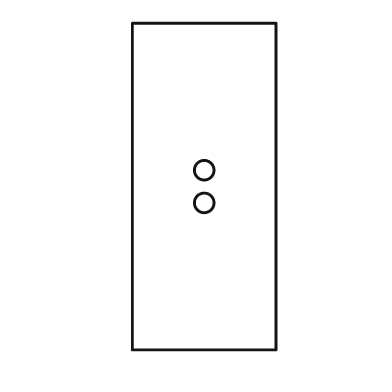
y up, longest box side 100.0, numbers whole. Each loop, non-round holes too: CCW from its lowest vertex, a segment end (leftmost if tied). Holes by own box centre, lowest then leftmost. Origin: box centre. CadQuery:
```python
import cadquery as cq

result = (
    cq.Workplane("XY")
    .moveTo(-22.0, -50.0)
    .lineTo(22.0, -50.0)
    .lineTo(22.0, 50.0)
    .lineTo(-22.0, 50.0)
    .close()
    .moveTo(0.0, -5.0)
    .circle(3.0)
    .moveTo(0.0, 5.0)
    .circle(3.0)
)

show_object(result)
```